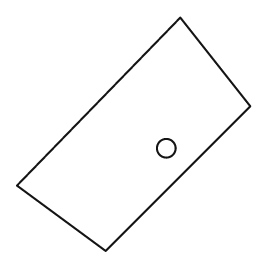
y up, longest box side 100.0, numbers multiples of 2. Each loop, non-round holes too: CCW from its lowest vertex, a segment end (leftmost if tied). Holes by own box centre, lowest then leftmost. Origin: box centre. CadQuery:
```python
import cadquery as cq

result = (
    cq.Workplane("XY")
    .moveTo(-12.0, -50.0)
    .lineTo(50.0, 12.0)
    .lineTo(20.0, 50.0)
    .lineTo(-50.0, -22.0)
    .close()
    .moveTo(14.0, -6.0)
    .circle(4.0)
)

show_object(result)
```